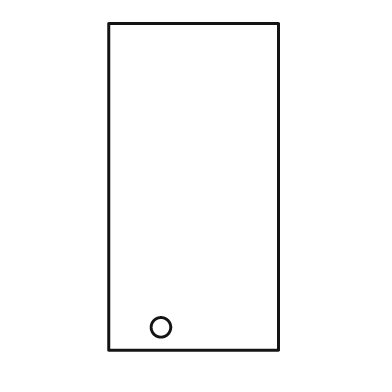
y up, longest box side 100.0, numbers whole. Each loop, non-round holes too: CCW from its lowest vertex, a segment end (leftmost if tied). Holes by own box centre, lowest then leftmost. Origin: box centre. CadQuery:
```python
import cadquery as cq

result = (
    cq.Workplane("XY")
    .moveTo(-26.0, -50.0)
    .lineTo(26.0, -50.0)
    .lineTo(26.0, 50.0)
    .lineTo(-26.0, 50.0)
    .close()
    .moveTo(-10.0, -43.0)
    .circle(3.0)
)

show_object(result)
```